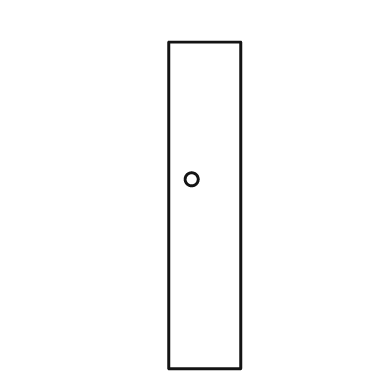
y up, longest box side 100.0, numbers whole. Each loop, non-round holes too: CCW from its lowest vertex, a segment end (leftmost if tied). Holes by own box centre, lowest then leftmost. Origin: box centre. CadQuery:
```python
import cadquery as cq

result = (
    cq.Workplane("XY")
    .moveTo(-11.0, -50.0)
    .lineTo(11.0, -50.0)
    .lineTo(11.0, 50.0)
    .lineTo(-11.0, 50.0)
    .close()
    .moveTo(-4.0, 8.0)
    .circle(2.0)
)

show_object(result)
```